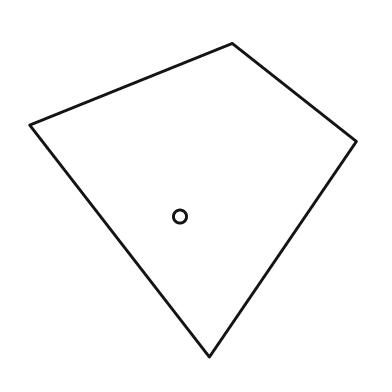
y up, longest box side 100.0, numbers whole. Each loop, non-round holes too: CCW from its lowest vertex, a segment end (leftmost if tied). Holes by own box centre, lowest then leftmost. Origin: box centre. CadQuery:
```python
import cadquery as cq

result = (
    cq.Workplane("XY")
    .moveTo(5.0, -48.0)
    .lineTo(50.0, 18.0)
    .lineTo(12.0, 48.0)
    .lineTo(-50.0, 23.0)
    .close()
    .moveTo(-4.0, -5.0)
    .circle(2.0)
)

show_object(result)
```